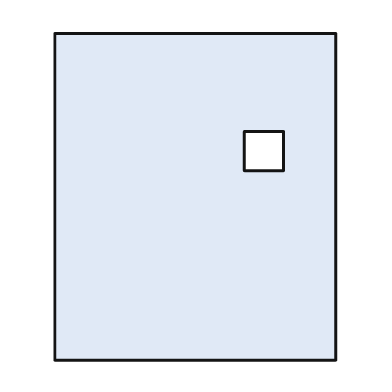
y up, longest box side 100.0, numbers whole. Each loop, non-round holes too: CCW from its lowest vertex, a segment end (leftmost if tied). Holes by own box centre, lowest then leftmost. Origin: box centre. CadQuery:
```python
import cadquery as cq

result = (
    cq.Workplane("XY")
    .moveTo(-43.0, -50.0)
    .lineTo(43.0, -50.0)
    .lineTo(43.0, 50.0)
    .lineTo(-43.0, 50.0)
    .close()
    .moveTo(15.0, 8.0)
    .lineTo(27.0, 8.0)
    .lineTo(27.0, 20.0)
    .lineTo(15.0, 20.0)
    .close()
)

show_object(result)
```